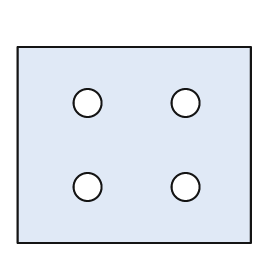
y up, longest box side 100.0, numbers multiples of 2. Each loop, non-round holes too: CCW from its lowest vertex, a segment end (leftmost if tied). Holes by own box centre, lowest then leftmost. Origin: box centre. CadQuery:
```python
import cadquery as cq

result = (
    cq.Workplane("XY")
    .moveTo(-50.0, -42.0)
    .lineTo(50.0, -42.0)
    .lineTo(50.0, 42.0)
    .lineTo(-50.0, 42.0)
    .close()
    .moveTo(-20.0, -18.0)
    .circle(6.0)
    .moveTo(22.0, -18.0)
    .circle(6.0)
    .moveTo(-20.0, 18.0)
    .circle(6.0)
    .moveTo(22.0, 18.0)
    .circle(6.0)
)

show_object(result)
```